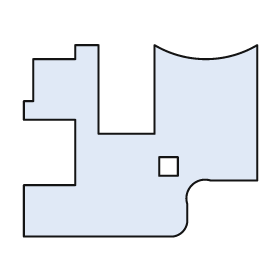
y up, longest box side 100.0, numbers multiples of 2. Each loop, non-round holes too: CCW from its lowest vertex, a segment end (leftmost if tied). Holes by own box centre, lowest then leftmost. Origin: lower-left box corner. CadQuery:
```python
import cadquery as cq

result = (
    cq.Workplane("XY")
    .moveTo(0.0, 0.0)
    .lineTo(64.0, 0.0)
    .threePointArc((68.0, 2.0), (70.0, 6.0))
    .lineTo(70.0, 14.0)
    .threePointArc((72.0, 22.0), (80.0, 24.0))
    .lineTo(100.0, 24.0)
    .lineTo(100.0, 82.0)
    .threePointArc((78.0, 76.0), (56.0, 82.0))
    .lineTo(56.0, 44.0)
    .lineTo(32.0, 44.0)
    .lineTo(32.0, 82.0)
    .lineTo(22.0, 82.0)
    .lineTo(22.0, 76.0)
    .lineTo(4.0, 76.0)
    .lineTo(4.0, 58.0)
    .lineTo(0.0, 58.0)
    .lineTo(0.0, 50.0)
    .lineTo(22.0, 50.0)
    .lineTo(22.0, 22.0)
    .lineTo(0.0, 22.0)
    .close()
    .moveTo(58.0, 26.0)
    .lineTo(66.0, 26.0)
    .lineTo(66.0, 34.0)
    .lineTo(58.0, 34.0)
    .close()
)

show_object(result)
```